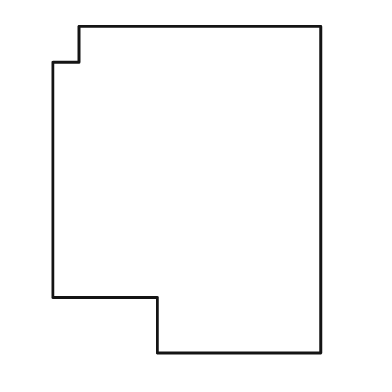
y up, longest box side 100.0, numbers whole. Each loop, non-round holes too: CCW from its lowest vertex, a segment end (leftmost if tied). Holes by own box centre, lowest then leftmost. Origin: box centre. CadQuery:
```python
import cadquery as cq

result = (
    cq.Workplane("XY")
    .moveTo(-9.0, -50.0)
    .lineTo(41.0, -50.0)
    .lineTo(41.0, 50.0)
    .lineTo(-33.0, 50.0)
    .lineTo(-33.0, 39.0)
    .lineTo(-41.0, 39.0)
    .lineTo(-41.0, -33.0)
    .lineTo(-9.0, -33.0)
    .close()
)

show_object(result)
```